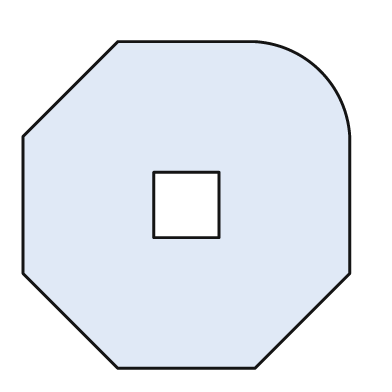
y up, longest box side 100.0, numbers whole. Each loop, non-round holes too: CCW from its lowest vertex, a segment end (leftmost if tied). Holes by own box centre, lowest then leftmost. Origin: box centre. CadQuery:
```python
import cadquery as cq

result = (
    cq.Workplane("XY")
    .moveTo(-21.0, -50.0)
    .lineTo(21.0, -50.0)
    .lineTo(50.0, -21.0)
    .lineTo(50.0, 21.0)
    .threePointArc((41.0, 41.0), (21.0, 50.0))
    .lineTo(-21.0, 50.0)
    .lineTo(-50.0, 21.0)
    .lineTo(-50.0, -21.0)
    .close()
    .moveTo(-10.0, -10.0)
    .lineTo(10.0, -10.0)
    .lineTo(10.0, 10.0)
    .lineTo(-10.0, 10.0)
    .close()
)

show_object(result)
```